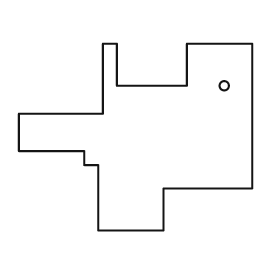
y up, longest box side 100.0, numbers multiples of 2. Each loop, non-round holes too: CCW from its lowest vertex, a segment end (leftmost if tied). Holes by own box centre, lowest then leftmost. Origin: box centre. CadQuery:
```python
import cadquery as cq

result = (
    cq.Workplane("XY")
    .moveTo(-16.0, -40.0)
    .lineTo(12.0, -40.0)
    .lineTo(12.0, -22.0)
    .lineTo(50.0, -22.0)
    .lineTo(50.0, 40.0)
    .lineTo(22.0, 40.0)
    .lineTo(22.0, 22.0)
    .lineTo(-8.0, 22.0)
    .lineTo(-8.0, 40.0)
    .lineTo(-14.0, 40.0)
    .lineTo(-14.0, 10.0)
    .lineTo(-50.0, 10.0)
    .lineTo(-50.0, -6.0)
    .lineTo(-22.0, -6.0)
    .lineTo(-22.0, -12.0)
    .lineTo(-16.0, -12.0)
    .close()
    .moveTo(38.0, 22.0)
    .circle(2.0)
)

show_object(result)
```